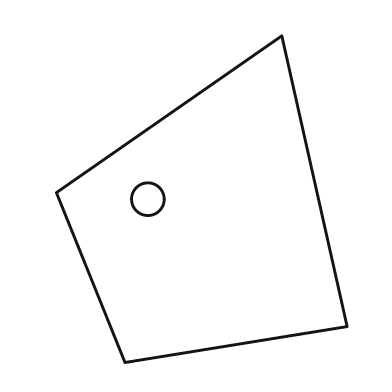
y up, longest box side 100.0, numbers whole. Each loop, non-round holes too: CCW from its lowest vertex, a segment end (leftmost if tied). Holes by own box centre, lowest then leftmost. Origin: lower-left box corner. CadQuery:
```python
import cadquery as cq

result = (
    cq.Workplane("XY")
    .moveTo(21.0, 0.0)
    .lineTo(89.0, 11.0)
    .lineTo(69.0, 100.0)
    .lineTo(0.0, 52.0)
    .close()
    .moveTo(28.0, 50.0)
    .circle(5.0)
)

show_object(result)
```